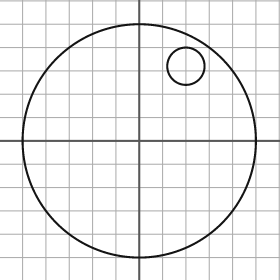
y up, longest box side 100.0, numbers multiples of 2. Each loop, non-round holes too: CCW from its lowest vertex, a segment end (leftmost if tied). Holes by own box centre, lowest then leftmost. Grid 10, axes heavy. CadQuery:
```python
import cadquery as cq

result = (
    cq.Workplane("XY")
    .moveTo(0.0, 0.0)
    .circle(50.0)
    .moveTo(20.0, 32.0)
    .circle(8.0)
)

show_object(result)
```